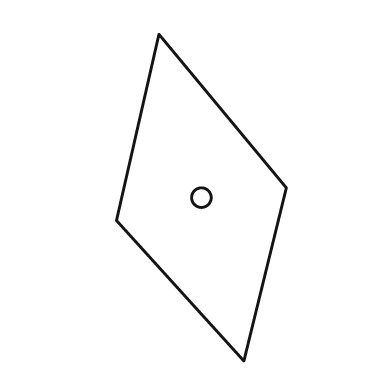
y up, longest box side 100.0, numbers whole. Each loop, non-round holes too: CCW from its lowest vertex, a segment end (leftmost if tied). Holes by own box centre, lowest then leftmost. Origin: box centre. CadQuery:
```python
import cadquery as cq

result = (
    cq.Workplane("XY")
    .moveTo(13.0, -50.0)
    .lineTo(26.0, 3.0)
    .lineTo(-13.0, 50.0)
    .lineTo(-26.0, -7.0)
    .close()
    .moveTo(0.0, 0.0)
    .circle(3.0)
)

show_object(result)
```